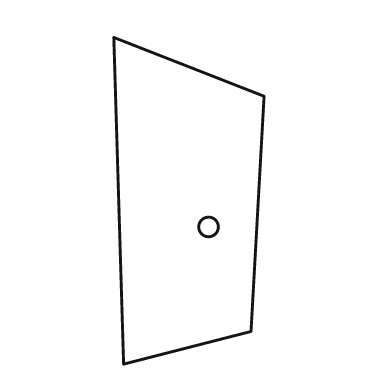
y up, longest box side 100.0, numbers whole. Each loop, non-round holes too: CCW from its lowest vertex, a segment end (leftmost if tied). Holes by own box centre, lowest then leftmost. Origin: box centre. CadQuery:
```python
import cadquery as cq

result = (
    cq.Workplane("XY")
    .moveTo(-20.0, -50.0)
    .lineTo(19.0, -40.0)
    .lineTo(23.0, 32.0)
    .lineTo(-23.0, 50.0)
    .close()
    .moveTo(6.0, -8.0)
    .circle(3.0)
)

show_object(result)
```